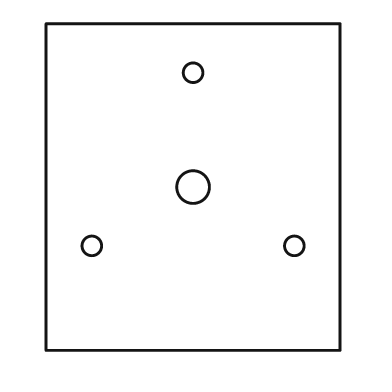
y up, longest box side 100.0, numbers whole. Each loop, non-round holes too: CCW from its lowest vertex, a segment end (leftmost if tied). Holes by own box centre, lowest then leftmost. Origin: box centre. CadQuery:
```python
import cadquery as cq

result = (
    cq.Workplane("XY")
    .moveTo(-45.0, -50.0)
    .lineTo(45.0, -50.0)
    .lineTo(45.0, 50.0)
    .lineTo(-45.0, 50.0)
    .close()
    .moveTo(-31.0, -18.0)
    .circle(3.0)
    .moveTo(31.0, -18.0)
    .circle(3.0)
    .moveTo(0.0, 0.0)
    .circle(5.0)
    .moveTo(0.0, 35.0)
    .circle(3.0)
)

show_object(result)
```